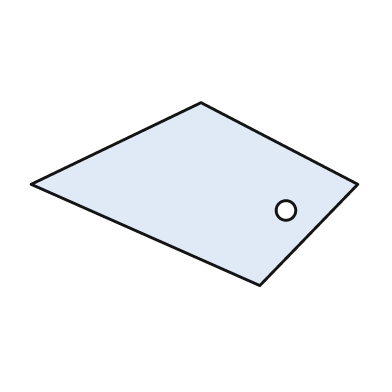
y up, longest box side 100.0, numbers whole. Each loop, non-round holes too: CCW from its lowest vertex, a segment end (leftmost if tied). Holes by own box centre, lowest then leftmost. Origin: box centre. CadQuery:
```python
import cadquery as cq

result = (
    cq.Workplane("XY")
    .moveTo(20.0, -28.0)
    .lineTo(50.0, 3.0)
    .lineTo(2.0, 28.0)
    .lineTo(-50.0, 3.0)
    .close()
    .moveTo(28.0, -5.0)
    .circle(3.0)
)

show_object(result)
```